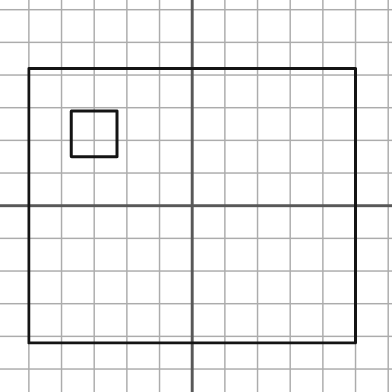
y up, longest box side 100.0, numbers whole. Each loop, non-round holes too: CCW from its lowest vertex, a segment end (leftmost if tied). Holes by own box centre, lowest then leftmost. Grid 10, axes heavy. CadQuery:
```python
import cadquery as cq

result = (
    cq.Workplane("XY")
    .moveTo(-50.0, -42.0)
    .lineTo(50.0, -42.0)
    .lineTo(50.0, 42.0)
    .lineTo(-50.0, 42.0)
    .close()
    .moveTo(-37.0, 15.0)
    .lineTo(-23.0, 15.0)
    .lineTo(-23.0, 29.0)
    .lineTo(-37.0, 29.0)
    .close()
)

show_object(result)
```